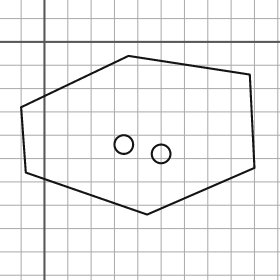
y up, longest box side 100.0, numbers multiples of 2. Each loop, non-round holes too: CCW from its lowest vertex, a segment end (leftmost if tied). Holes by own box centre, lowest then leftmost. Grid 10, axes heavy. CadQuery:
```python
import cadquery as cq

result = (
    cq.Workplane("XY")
    .moveTo(44.0, -74.0)
    .lineTo(90.0, -54.0)
    .lineTo(88.0, -14.0)
    .lineTo(36.0, -6.0)
    .lineTo(-10.0, -28.0)
    .lineTo(-8.0, -56.0)
    .close()
    .moveTo(50.0, -48.0)
    .circle(4.0)
    .moveTo(34.0, -44.0)
    .circle(4.0)
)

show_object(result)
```